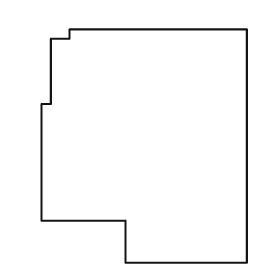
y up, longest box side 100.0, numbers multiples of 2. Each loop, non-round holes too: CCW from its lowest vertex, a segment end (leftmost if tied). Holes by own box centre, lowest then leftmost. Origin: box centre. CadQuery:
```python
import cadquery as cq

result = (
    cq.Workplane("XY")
    .moveTo(-8.0, -50.0)
    .lineTo(44.0, -50.0)
    .lineTo(44.0, 50.0)
    .lineTo(-32.0, 50.0)
    .lineTo(-32.0, 46.0)
    .lineTo(-40.0, 46.0)
    .lineTo(-40.0, 18.0)
    .lineTo(-44.0, 18.0)
    .lineTo(-44.0, -32.0)
    .lineTo(-8.0, -32.0)
    .close()
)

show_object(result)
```